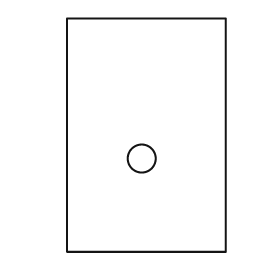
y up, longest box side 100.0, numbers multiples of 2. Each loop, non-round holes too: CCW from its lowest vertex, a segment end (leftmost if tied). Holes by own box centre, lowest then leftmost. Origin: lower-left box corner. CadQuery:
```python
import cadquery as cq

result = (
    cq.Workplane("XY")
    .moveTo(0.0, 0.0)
    .lineTo(68.0, 0.0)
    .lineTo(68.0, 100.0)
    .lineTo(0.0, 100.0)
    .close()
    .moveTo(32.0, 40.0)
    .circle(6.0)
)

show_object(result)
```